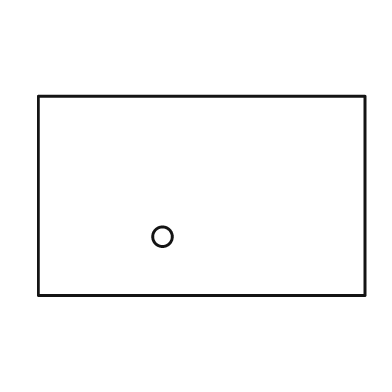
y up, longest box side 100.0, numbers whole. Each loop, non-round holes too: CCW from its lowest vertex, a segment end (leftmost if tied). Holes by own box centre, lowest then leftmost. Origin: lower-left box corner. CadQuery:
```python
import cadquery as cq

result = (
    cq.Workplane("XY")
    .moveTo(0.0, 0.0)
    .lineTo(100.0, 0.0)
    .lineTo(100.0, 61.0)
    .lineTo(0.0, 61.0)
    .close()
    .moveTo(38.0, 18.0)
    .circle(3.0)
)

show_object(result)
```